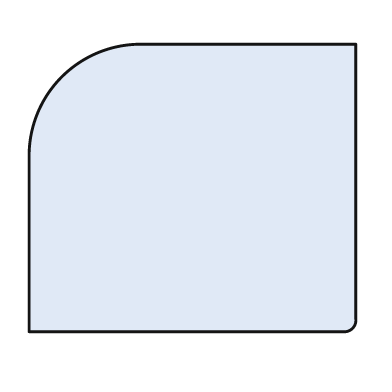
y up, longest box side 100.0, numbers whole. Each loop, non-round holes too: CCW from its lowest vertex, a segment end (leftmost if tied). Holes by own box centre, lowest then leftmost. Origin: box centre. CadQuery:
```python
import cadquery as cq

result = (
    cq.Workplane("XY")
    .moveTo(-50.0, -44.0)
    .lineTo(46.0, -44.0)
    .threePointArc((49.0, -43.0), (50.0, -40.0))
    .lineTo(50.0, 44.0)
    .lineTo(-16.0, 44.0)
    .threePointArc((-40.0, 34.0), (-50.0, 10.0))
    .close()
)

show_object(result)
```